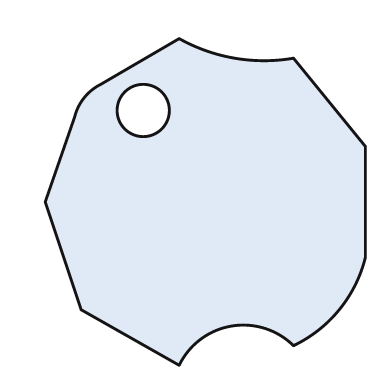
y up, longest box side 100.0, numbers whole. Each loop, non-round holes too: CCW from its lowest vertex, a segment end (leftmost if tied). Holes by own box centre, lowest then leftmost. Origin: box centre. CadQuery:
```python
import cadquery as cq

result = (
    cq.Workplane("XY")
    .moveTo(-8.0, -50.0)
    .threePointArc((8.0, -38.0), (27.0, -44.0))
    .threePointArc((41.0, -33.0), (49.0, -17.0))
    .lineTo(49.0, 17.0)
    .lineTo(27.0, 44.0)
    .threePointArc((9.0, 44.0), (-8.0, 50.0))
    .lineTo(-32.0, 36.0)
    .threePointArc((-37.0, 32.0), (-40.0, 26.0))
    .lineTo(-49.0, 0.0)
    .lineTo(-38.0, -33.0)
    .close()
    .moveTo(-19.0, 28.0)
    .circle(8.0)
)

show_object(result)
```